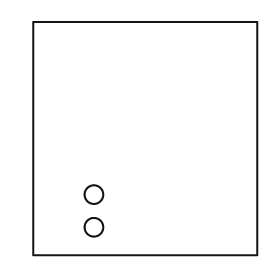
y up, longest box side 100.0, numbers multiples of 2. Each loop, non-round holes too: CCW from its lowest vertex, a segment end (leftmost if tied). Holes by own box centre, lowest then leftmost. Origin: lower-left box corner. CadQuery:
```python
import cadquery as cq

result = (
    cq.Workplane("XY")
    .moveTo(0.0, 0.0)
    .lineTo(96.0, 0.0)
    .lineTo(96.0, 100.0)
    .lineTo(0.0, 100.0)
    .close()
    .moveTo(26.0, 12.0)
    .circle(4.0)
    .moveTo(26.0, 26.0)
    .circle(4.0)
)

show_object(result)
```